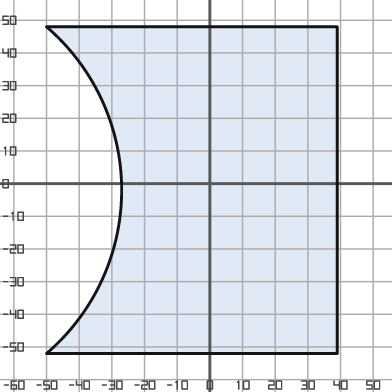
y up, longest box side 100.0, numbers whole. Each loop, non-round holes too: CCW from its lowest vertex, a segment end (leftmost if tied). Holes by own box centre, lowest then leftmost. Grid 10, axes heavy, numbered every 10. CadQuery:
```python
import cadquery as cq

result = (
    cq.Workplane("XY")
    .moveTo(-50.0, -52.0)
    .lineTo(39.0, -52.0)
    .lineTo(39.0, 48.0)
    .lineTo(-50.0, 48.0)
    .threePointArc((-27.0, -2.0), (-50.0, -52.0))
    .close()
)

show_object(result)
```